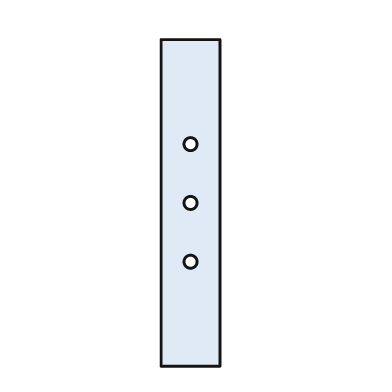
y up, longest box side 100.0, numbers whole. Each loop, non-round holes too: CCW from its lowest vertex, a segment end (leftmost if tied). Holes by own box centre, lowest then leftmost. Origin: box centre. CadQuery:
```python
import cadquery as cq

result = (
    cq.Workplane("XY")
    .moveTo(-9.0, -50.0)
    .lineTo(9.0, -50.0)
    .lineTo(9.0, 50.0)
    .lineTo(-9.0, 50.0)
    .close()
    .moveTo(0.0, -18.0)
    .circle(2.0)
    .moveTo(0.0, 0.0)
    .circle(2.0)
    .moveTo(0.0, 18.0)
    .circle(2.0)
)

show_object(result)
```